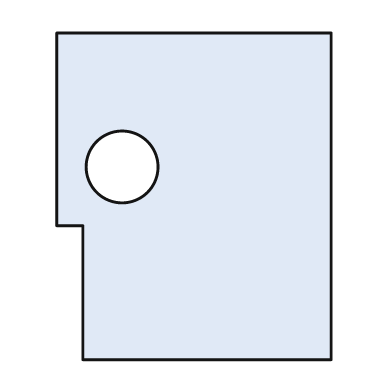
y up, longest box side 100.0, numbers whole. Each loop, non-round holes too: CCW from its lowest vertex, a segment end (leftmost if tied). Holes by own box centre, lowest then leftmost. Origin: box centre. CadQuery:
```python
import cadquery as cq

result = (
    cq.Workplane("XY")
    .moveTo(-34.0, -50.0)
    .lineTo(42.0, -50.0)
    .lineTo(42.0, 50.0)
    .lineTo(-42.0, 50.0)
    .lineTo(-42.0, -9.0)
    .lineTo(-34.0, -9.0)
    .close()
    .moveTo(-22.0, 9.0)
    .circle(11.0)
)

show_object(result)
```